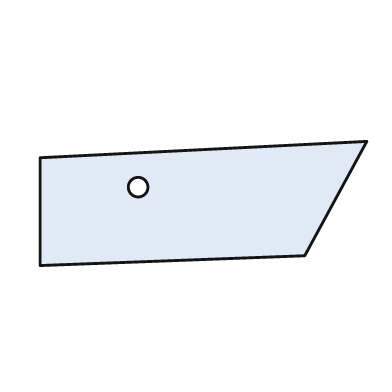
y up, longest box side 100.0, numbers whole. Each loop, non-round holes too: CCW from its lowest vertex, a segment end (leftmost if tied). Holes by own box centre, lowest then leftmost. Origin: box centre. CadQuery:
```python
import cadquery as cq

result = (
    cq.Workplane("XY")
    .moveTo(-50.0, -19.0)
    .lineTo(31.0, -16.0)
    .lineTo(50.0, 19.0)
    .lineTo(-50.0, 14.0)
    .close()
    .moveTo(-20.0, 5.0)
    .circle(3.0)
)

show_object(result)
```